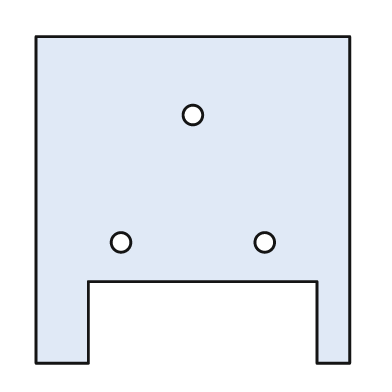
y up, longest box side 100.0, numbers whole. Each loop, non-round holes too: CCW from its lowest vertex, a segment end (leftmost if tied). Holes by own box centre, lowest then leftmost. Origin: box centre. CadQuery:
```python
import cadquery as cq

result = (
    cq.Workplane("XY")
    .moveTo(-48.0, -50.0)
    .lineTo(-32.0, -50.0)
    .lineTo(-32.0, -25.0)
    .lineTo(38.0, -25.0)
    .lineTo(38.0, -50.0)
    .lineTo(48.0, -50.0)
    .lineTo(48.0, 50.0)
    .lineTo(-48.0, 50.0)
    .close()
    .moveTo(-22.0, -13.0)
    .circle(3.0)
    .moveTo(22.0, -13.0)
    .circle(3.0)
    .moveTo(0.0, 26.0)
    .circle(3.0)
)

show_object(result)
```